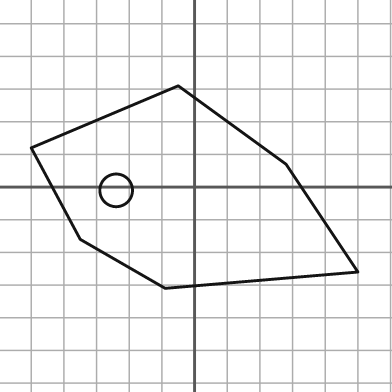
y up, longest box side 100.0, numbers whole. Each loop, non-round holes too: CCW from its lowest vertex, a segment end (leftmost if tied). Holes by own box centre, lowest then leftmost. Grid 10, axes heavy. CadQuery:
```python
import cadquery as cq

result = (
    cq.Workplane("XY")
    .moveTo(-9.0, -31.0)
    .lineTo(50.0, -26.0)
    .lineTo(28.0, 7.0)
    .lineTo(-5.0, 31.0)
    .lineTo(-50.0, 12.0)
    .lineTo(-35.0, -16.0)
    .close()
    .moveTo(-24.0, -1.0)
    .circle(5.0)
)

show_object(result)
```